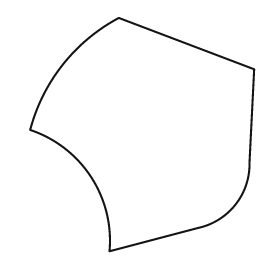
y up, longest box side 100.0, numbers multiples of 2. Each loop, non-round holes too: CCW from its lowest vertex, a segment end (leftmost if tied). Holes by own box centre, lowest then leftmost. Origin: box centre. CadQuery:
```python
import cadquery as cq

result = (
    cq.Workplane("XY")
    .moveTo(-14.0, -50.0)
    .lineTo(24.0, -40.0)
    .threePointArc((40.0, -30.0), (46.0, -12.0))
    .lineTo(48.0, 28.0)
    .lineTo(-10.0, 50.0)
    .threePointArc((-34.0, 30.0), (-48.0, 2.0))
    .threePointArc((-22.0, -18.0), (-14.0, -50.0))
    .close()
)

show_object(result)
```